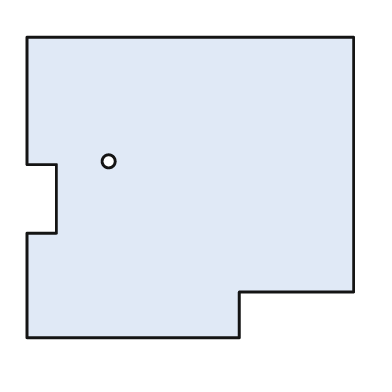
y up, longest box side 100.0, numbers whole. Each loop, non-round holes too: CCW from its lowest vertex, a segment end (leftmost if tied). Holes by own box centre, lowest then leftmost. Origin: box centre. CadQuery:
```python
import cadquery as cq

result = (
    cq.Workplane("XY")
    .moveTo(-50.0, -46.0)
    .lineTo(15.0, -46.0)
    .lineTo(15.0, -32.0)
    .lineTo(50.0, -32.0)
    .lineTo(50.0, 46.0)
    .lineTo(-50.0, 46.0)
    .lineTo(-50.0, 7.0)
    .lineTo(-41.0, 7.0)
    .lineTo(-41.0, -14.0)
    .lineTo(-50.0, -14.0)
    .close()
    .moveTo(-25.0, 8.0)
    .circle(2.0)
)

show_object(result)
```